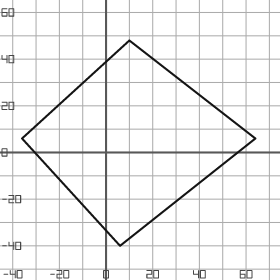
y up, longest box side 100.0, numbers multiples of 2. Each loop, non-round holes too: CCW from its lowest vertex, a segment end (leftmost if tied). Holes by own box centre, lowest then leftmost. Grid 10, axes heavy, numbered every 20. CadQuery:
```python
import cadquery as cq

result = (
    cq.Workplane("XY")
    .moveTo(6.0, -40.0)
    .lineTo(64.0, 6.0)
    .lineTo(10.0, 48.0)
    .lineTo(-36.0, 6.0)
    .close()
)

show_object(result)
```